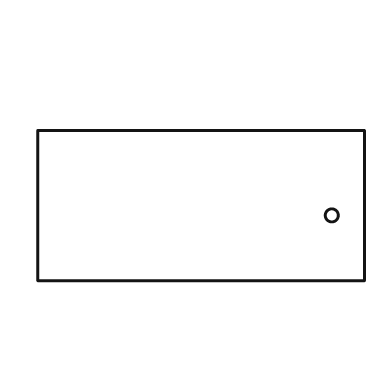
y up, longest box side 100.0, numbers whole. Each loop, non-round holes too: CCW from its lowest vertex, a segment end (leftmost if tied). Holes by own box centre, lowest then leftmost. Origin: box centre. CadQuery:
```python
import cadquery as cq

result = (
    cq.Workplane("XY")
    .moveTo(-50.0, -23.0)
    .lineTo(50.0, -23.0)
    .lineTo(50.0, 23.0)
    .lineTo(-50.0, 23.0)
    .close()
    .moveTo(40.0, -3.0)
    .circle(2.0)
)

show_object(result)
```